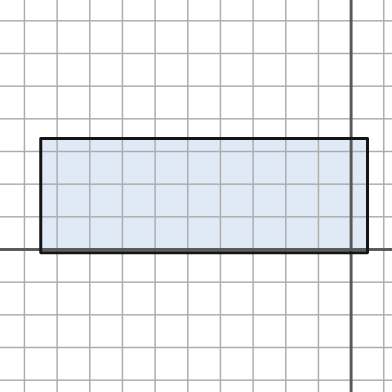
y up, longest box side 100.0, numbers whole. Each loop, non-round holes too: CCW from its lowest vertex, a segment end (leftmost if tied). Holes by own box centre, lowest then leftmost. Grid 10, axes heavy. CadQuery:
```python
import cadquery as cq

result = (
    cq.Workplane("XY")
    .moveTo(-95.0, -1.0)
    .lineTo(5.0, -1.0)
    .lineTo(5.0, 34.0)
    .lineTo(-95.0, 34.0)
    .close()
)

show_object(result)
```